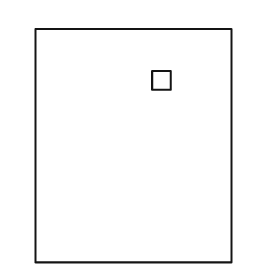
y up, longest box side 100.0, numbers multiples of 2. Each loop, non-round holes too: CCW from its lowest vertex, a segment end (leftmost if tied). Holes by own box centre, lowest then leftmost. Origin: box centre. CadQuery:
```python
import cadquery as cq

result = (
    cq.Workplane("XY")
    .moveTo(-42.0, -50.0)
    .lineTo(42.0, -50.0)
    .lineTo(42.0, 50.0)
    .lineTo(-42.0, 50.0)
    .close()
    .moveTo(8.0, 24.0)
    .lineTo(16.0, 24.0)
    .lineTo(16.0, 32.0)
    .lineTo(8.0, 32.0)
    .close()
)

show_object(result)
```